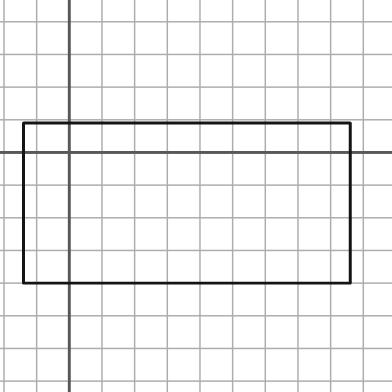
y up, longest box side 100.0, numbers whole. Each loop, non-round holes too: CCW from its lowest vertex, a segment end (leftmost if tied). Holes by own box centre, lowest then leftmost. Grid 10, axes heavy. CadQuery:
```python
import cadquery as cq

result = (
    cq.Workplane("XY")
    .moveTo(-14.0, -40.0)
    .lineTo(86.0, -40.0)
    .lineTo(86.0, 9.0)
    .lineTo(-14.0, 9.0)
    .close()
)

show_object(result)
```